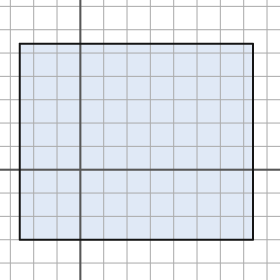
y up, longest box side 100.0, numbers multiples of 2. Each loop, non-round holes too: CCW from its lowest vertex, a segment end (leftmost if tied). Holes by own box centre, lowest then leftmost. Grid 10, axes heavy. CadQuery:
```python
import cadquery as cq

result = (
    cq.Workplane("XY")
    .moveTo(-26.0, -30.0)
    .lineTo(74.0, -30.0)
    .lineTo(74.0, 54.0)
    .lineTo(-26.0, 54.0)
    .close()
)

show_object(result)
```